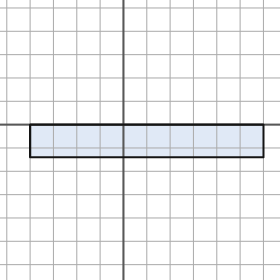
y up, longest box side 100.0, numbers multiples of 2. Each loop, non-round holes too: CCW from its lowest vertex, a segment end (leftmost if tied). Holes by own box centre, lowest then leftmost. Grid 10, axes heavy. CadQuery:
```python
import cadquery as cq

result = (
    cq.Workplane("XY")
    .moveTo(-40.0, -14.0)
    .lineTo(60.0, -14.0)
    .lineTo(60.0, 0.0)
    .lineTo(-40.0, 0.0)
    .close()
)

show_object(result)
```